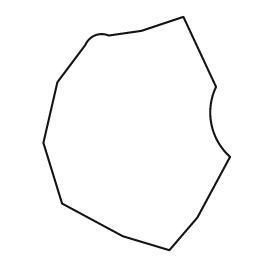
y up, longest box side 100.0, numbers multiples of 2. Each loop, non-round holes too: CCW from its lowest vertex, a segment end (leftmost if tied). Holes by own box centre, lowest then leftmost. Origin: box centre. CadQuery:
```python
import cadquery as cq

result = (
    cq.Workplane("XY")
    .moveTo(14.0, -50.0)
    .lineTo(26.0, -36.0)
    .lineTo(40.0, -10.0)
    .threePointArc((32.0, 4.0), (34.0, 20.0))
    .lineTo(20.0, 50.0)
    .lineTo(2.0, 44.0)
    .lineTo(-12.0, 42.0)
    .threePointArc((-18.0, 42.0), (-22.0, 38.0))
    .lineTo(-34.0, 22.0)
    .lineTo(-40.0, -4.0)
    .lineTo(-32.0, -30.0)
    .lineTo(-6.0, -44.0)
    .close()
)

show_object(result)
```